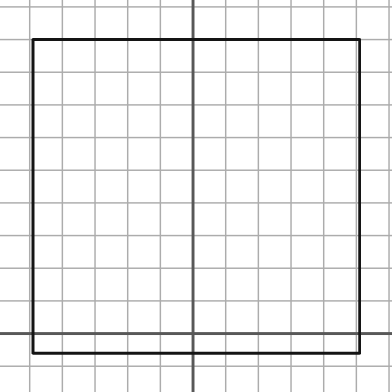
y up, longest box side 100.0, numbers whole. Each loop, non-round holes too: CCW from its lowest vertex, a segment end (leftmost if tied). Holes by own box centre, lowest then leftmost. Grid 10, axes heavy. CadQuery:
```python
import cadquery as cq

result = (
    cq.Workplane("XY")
    .moveTo(-49.0, -6.0)
    .lineTo(51.0, -6.0)
    .lineTo(51.0, 90.0)
    .lineTo(-49.0, 90.0)
    .close()
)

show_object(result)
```